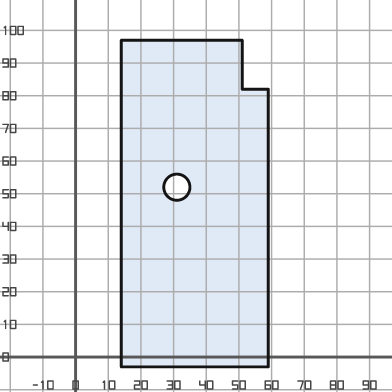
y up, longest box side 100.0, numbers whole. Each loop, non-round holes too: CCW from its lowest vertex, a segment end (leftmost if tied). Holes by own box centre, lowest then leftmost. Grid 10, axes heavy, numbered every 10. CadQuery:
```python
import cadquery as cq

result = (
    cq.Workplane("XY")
    .moveTo(14.0, -3.0)
    .lineTo(59.0, -3.0)
    .lineTo(59.0, 82.0)
    .lineTo(51.0, 82.0)
    .lineTo(51.0, 97.0)
    .lineTo(14.0, 97.0)
    .close()
    .moveTo(31.0, 52.0)
    .circle(4.0)
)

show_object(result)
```